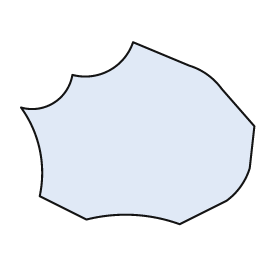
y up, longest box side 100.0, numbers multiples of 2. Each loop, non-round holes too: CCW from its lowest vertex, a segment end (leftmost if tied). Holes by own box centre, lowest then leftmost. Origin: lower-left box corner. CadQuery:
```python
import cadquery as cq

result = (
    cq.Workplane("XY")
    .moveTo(68.0, 0.0)
    .lineTo(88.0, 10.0)
    .threePointArc((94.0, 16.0), (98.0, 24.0))
    .lineTo(100.0, 42.0)
    .lineTo(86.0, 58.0)
    .threePointArc((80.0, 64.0), (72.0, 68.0))
    .lineTo(48.0, 78.0)
    .threePointArc((38.0, 66.0), (22.0, 64.0))
    .threePointArc((14.0, 52.0), (0.0, 50.0))
    .threePointArc((8.0, 32.0), (8.0, 12.0))
    .lineTo(28.0, 2.0)
    .threePointArc((48.0, 4.0), (68.0, 0.0))
    .close()
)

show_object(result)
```